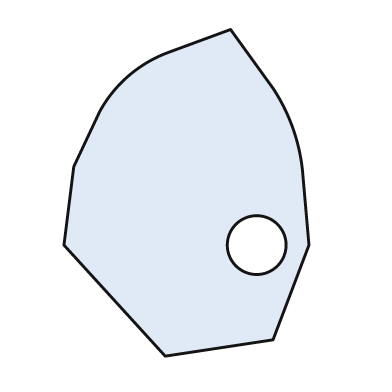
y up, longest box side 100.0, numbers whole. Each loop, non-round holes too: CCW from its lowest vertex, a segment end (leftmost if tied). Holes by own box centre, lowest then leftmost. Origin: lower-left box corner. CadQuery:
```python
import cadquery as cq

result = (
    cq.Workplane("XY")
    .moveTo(31.0, 0.0)
    .lineTo(64.0, 5.0)
    .lineTo(75.0, 34.0)
    .lineTo(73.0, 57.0)
    .threePointArc((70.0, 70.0), (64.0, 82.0))
    .lineTo(51.0, 100.0)
    .lineTo(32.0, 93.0)
    .threePointArc((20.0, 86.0), (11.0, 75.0))
    .lineTo(3.0, 58.0)
    .lineTo(0.0, 34.0)
    .close()
    .moveTo(59.0, 34.0)
    .circle(9.0)
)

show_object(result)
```